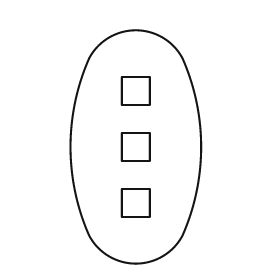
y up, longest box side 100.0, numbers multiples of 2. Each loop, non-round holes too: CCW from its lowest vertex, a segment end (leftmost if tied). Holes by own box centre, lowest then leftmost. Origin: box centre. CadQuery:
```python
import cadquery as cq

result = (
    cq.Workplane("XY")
    .moveTo(-20.0, -38.0)
    .threePointArc((0.0, -50.0), (20.0, -38.0))
    .threePointArc((28.0, 0.0), (20.0, 38.0))
    .threePointArc((0.0, 50.0), (-20.0, 38.0))
    .threePointArc((-28.0, 0.0), (-20.0, -38.0))
    .close()
    .moveTo(-6.0, -30.0)
    .lineTo(6.0, -30.0)
    .lineTo(6.0, -18.0)
    .lineTo(-6.0, -18.0)
    .close()
    .moveTo(-6.0, -6.0)
    .lineTo(6.0, -6.0)
    .lineTo(6.0, 6.0)
    .lineTo(-6.0, 6.0)
    .close()
    .moveTo(-6.0, 18.0)
    .lineTo(6.0, 18.0)
    .lineTo(6.0, 30.0)
    .lineTo(-6.0, 30.0)
    .close()
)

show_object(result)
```